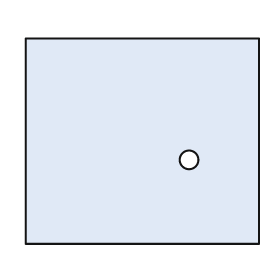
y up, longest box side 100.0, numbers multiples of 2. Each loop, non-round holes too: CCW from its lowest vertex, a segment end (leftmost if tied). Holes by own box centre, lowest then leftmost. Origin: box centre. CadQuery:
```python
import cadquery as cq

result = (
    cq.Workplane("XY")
    .moveTo(-50.0, -44.0)
    .lineTo(50.0, -44.0)
    .lineTo(50.0, 44.0)
    .lineTo(-50.0, 44.0)
    .close()
    .moveTo(20.0, -8.0)
    .circle(4.0)
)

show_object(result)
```